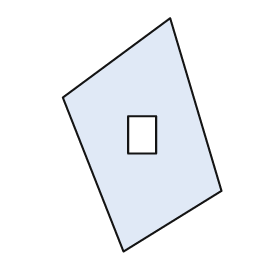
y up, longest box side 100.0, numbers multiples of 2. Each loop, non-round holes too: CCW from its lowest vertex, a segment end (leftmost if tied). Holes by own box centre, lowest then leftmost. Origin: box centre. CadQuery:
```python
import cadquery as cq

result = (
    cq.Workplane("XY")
    .moveTo(-8.0, -50.0)
    .lineTo(34.0, -24.0)
    .lineTo(12.0, 50.0)
    .lineTo(-34.0, 16.0)
    .close()
    .moveTo(-6.0, -8.0)
    .lineTo(6.0, -8.0)
    .lineTo(6.0, 8.0)
    .lineTo(-6.0, 8.0)
    .close()
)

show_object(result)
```